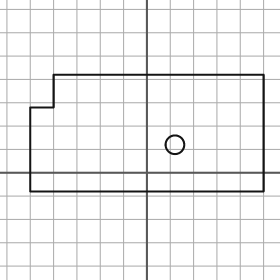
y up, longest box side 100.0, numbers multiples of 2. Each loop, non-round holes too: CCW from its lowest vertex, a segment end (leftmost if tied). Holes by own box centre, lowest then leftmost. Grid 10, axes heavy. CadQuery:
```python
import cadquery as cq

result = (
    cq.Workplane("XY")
    .moveTo(-50.0, -8.0)
    .lineTo(50.0, -8.0)
    .lineTo(50.0, 42.0)
    .lineTo(-40.0, 42.0)
    .lineTo(-40.0, 28.0)
    .lineTo(-50.0, 28.0)
    .close()
    .moveTo(12.0, 12.0)
    .circle(4.0)
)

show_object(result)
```